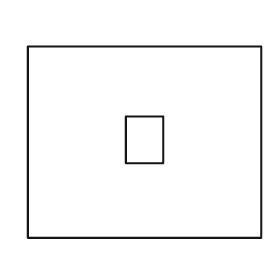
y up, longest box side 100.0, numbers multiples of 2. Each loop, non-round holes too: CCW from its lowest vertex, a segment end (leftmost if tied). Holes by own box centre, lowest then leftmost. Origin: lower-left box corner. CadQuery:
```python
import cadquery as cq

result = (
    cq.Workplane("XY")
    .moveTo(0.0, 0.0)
    .lineTo(100.0, 0.0)
    .lineTo(100.0, 82.0)
    .lineTo(0.0, 82.0)
    .close()
    .moveTo(42.0, 32.0)
    .lineTo(58.0, 32.0)
    .lineTo(58.0, 52.0)
    .lineTo(42.0, 52.0)
    .close()
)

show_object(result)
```